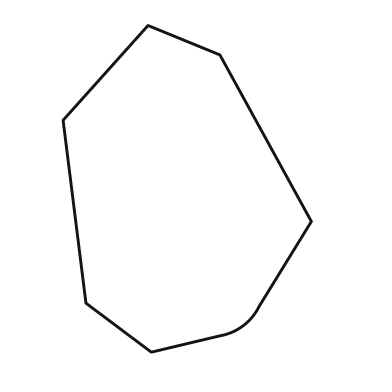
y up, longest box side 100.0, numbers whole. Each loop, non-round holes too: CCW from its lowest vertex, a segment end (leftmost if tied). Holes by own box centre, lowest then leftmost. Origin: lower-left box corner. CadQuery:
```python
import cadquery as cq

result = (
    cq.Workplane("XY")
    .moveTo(27.0, 0.0)
    .lineTo(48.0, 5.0)
    .threePointArc((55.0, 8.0), (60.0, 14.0))
    .lineTo(76.0, 40.0)
    .lineTo(48.0, 91.0)
    .lineTo(26.0, 100.0)
    .lineTo(0.0, 71.0)
    .lineTo(7.0, 15.0)
    .close()
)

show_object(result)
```